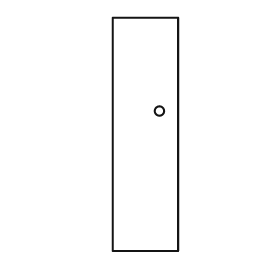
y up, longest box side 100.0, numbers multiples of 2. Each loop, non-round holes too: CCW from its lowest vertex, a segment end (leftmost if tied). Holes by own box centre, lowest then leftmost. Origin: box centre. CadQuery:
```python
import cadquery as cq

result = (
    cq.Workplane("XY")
    .moveTo(-14.0, -50.0)
    .lineTo(14.0, -50.0)
    .lineTo(14.0, 50.0)
    .lineTo(-14.0, 50.0)
    .close()
    .moveTo(6.0, 10.0)
    .circle(2.0)
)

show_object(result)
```